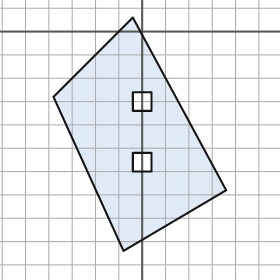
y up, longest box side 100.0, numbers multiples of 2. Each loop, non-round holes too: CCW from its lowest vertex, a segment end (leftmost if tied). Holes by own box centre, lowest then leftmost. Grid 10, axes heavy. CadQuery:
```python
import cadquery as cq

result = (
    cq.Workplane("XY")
    .moveTo(-8.0, -94.0)
    .lineTo(36.0, -68.0)
    .lineTo(-4.0, 6.0)
    .lineTo(-38.0, -28.0)
    .close()
    .moveTo(-4.0, -60.0)
    .lineTo(4.0, -60.0)
    .lineTo(4.0, -52.0)
    .lineTo(-4.0, -52.0)
    .close()
    .moveTo(-4.0, -34.0)
    .lineTo(4.0, -34.0)
    .lineTo(4.0, -26.0)
    .lineTo(-4.0, -26.0)
    .close()
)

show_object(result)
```